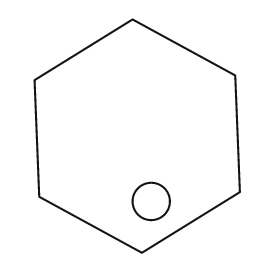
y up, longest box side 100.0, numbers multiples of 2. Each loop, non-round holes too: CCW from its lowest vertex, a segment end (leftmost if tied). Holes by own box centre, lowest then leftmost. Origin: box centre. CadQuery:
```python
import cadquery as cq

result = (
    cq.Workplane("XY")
    .moveTo(2.0, -50.0)
    .lineTo(44.0, -24.0)
    .lineTo(42.0, 26.0)
    .lineTo(-2.0, 50.0)
    .lineTo(-44.0, 24.0)
    .lineTo(-42.0, -26.0)
    .close()
    .moveTo(6.0, -28.0)
    .circle(8.0)
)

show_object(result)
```